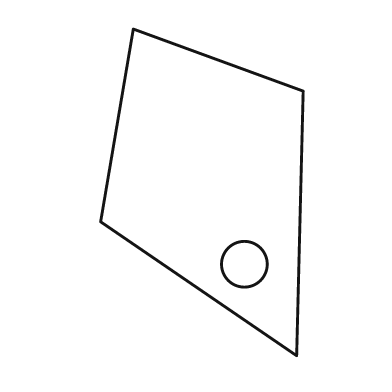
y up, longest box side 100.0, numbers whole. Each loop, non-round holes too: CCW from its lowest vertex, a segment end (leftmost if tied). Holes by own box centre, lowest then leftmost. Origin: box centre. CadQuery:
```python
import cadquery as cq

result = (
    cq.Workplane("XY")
    .moveTo(29.0, -50.0)
    .lineTo(31.0, 31.0)
    .lineTo(-21.0, 50.0)
    .lineTo(-31.0, -9.0)
    .close()
    .moveTo(13.0, -22.0)
    .circle(7.0)
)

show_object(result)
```